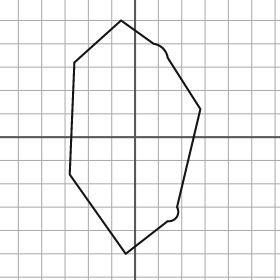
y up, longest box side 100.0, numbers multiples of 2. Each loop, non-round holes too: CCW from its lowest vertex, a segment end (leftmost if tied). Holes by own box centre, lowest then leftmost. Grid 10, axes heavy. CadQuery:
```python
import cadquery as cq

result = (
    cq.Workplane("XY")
    .moveTo(-4.0, -50.0)
    .lineTo(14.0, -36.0)
    .threePointArc((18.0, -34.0), (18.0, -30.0))
    .lineTo(28.0, 12.0)
    .lineTo(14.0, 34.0)
    .threePointArc((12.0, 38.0), (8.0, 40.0))
    .lineTo(-6.0, 50.0)
    .lineTo(-26.0, 32.0)
    .lineTo(-28.0, -16.0)
    .close()
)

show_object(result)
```